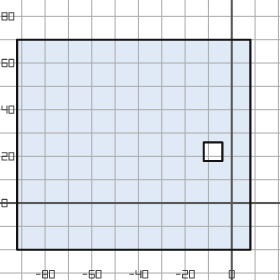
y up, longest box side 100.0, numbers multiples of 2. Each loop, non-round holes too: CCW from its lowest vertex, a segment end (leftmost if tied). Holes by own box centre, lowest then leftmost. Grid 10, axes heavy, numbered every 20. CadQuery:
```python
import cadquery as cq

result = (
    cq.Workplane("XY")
    .moveTo(-92.0, -20.0)
    .lineTo(8.0, -20.0)
    .lineTo(8.0, 70.0)
    .lineTo(-92.0, 70.0)
    .close()
    .moveTo(-12.0, 18.0)
    .lineTo(-4.0, 18.0)
    .lineTo(-4.0, 26.0)
    .lineTo(-12.0, 26.0)
    .close()
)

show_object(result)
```